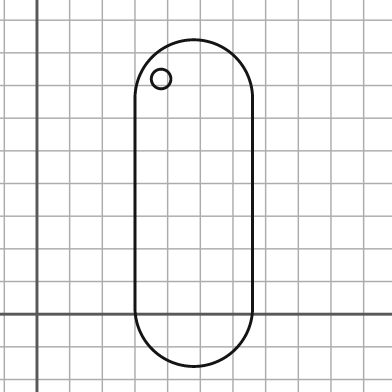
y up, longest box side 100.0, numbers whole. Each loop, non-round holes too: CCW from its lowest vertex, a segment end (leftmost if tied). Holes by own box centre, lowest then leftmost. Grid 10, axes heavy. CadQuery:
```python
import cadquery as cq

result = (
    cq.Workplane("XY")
    .moveTo(30.0, 2.0)
    .threePointArc((48.0, -16.0), (66.0, 2.0))
    .lineTo(66.0, 66.0)
    .threePointArc((48.0, 84.0), (30.0, 66.0))
    .close()
    .moveTo(38.0, 72.0)
    .circle(3.0)
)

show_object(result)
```